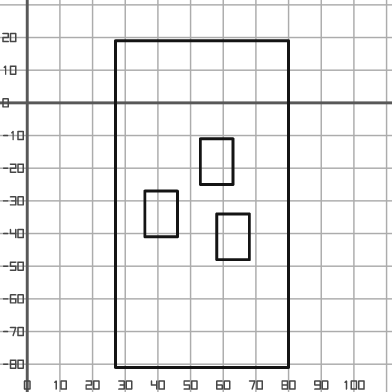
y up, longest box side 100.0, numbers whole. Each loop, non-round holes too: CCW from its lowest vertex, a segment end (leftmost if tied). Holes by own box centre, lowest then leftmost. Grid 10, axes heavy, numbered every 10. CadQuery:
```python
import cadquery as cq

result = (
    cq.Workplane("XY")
    .moveTo(27.0, -81.0)
    .lineTo(80.0, -81.0)
    .lineTo(80.0, 19.0)
    .lineTo(27.0, 19.0)
    .close()
    .moveTo(58.0, -48.0)
    .lineTo(68.0, -48.0)
    .lineTo(68.0, -34.0)
    .lineTo(58.0, -34.0)
    .close()
    .moveTo(36.0, -41.0)
    .lineTo(46.0, -41.0)
    .lineTo(46.0, -27.0)
    .lineTo(36.0, -27.0)
    .close()
    .moveTo(53.0, -25.0)
    .lineTo(63.0, -25.0)
    .lineTo(63.0, -11.0)
    .lineTo(53.0, -11.0)
    .close()
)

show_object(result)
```